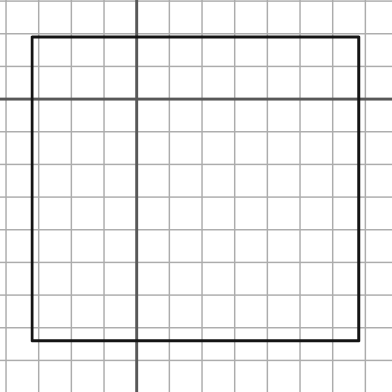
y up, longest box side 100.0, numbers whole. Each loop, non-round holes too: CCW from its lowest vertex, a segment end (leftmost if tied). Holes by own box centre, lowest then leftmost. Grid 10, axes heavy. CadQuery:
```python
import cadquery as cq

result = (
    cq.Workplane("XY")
    .moveTo(-32.0, -74.0)
    .lineTo(68.0, -74.0)
    .lineTo(68.0, 19.0)
    .lineTo(-32.0, 19.0)
    .close()
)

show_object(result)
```